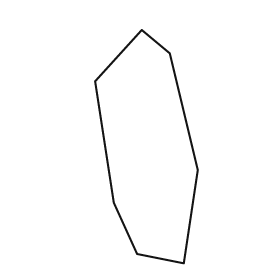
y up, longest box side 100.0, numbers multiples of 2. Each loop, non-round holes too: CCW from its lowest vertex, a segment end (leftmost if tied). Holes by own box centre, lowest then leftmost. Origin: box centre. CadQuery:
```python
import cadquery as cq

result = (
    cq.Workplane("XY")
    .moveTo(16.0, -50.0)
    .lineTo(22.0, -10.0)
    .lineTo(10.0, 40.0)
    .lineTo(-2.0, 50.0)
    .lineTo(-22.0, 28.0)
    .lineTo(-14.0, -24.0)
    .lineTo(-4.0, -46.0)
    .close()
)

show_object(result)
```